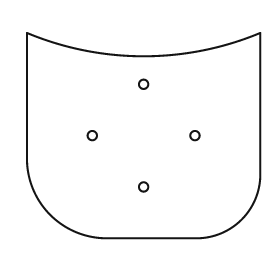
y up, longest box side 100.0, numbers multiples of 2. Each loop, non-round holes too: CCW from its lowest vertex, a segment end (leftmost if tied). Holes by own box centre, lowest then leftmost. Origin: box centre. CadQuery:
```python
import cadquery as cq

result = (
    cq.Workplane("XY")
    .moveTo(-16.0, -44.0)
    .lineTo(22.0, -44.0)
    .threePointArc((42.0, -36.0), (50.0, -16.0))
    .lineTo(50.0, 44.0)
    .threePointArc((0.0, 34.0), (-50.0, 44.0))
    .lineTo(-50.0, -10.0)
    .threePointArc((-40.0, -34.0), (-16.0, -44.0))
    .close()
    .moveTo(0.0, -22.0)
    .circle(2.0)
    .moveTo(-22.0, 0.0)
    .circle(2.0)
    .moveTo(22.0, 0.0)
    .circle(2.0)
    .moveTo(0.0, 22.0)
    .circle(2.0)
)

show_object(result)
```